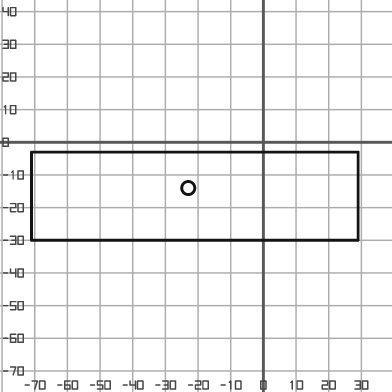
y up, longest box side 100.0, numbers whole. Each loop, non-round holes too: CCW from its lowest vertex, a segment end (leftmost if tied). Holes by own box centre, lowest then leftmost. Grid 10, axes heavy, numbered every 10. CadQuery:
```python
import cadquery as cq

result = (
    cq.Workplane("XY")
    .moveTo(-71.0, -30.0)
    .lineTo(29.0, -30.0)
    .lineTo(29.0, -3.0)
    .lineTo(-71.0, -3.0)
    .close()
    .moveTo(-23.0, -14.0)
    .circle(2.0)
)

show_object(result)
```